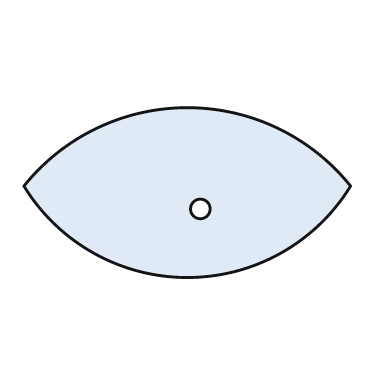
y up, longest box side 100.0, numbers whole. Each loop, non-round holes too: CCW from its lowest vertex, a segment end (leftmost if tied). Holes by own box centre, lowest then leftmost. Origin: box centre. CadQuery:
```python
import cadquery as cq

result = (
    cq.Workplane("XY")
    .moveTo(-50.0, 2.0)
    .threePointArc((0.0, -26.0), (50.0, 2.0))
    .threePointArc((0.0, 26.0), (-50.0, 2.0))
    .close()
    .moveTo(4.0, -5.0)
    .circle(3.0)
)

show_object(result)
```